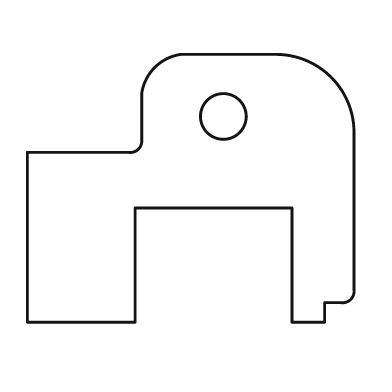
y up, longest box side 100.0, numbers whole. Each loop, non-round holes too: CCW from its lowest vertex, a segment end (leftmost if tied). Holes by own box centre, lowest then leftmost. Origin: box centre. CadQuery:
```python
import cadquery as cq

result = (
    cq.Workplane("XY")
    .moveTo(-50.0, -41.0)
    .lineTo(-17.0, -41.0)
    .lineTo(-17.0, -6.0)
    .lineTo(31.0, -6.0)
    .lineTo(31.0, -41.0)
    .lineTo(41.0, -41.0)
    .lineTo(41.0, -35.0)
    .lineTo(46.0, -35.0)
    .threePointArc((49.0, -34.0), (50.0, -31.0))
    .lineTo(50.0, 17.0)
    .threePointArc((43.0, 34.0), (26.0, 41.0))
    .lineTo(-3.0, 41.0)
    .threePointArc((-11.0, 37.0), (-15.0, 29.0))
    .lineTo(-15.0, 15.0)
    .threePointArc((-16.0, 12.0), (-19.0, 11.0))
    .lineTo(-50.0, 11.0)
    .close()
    .moveTo(10.0, 22.0)
    .circle(7.0)
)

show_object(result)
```